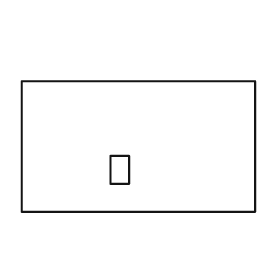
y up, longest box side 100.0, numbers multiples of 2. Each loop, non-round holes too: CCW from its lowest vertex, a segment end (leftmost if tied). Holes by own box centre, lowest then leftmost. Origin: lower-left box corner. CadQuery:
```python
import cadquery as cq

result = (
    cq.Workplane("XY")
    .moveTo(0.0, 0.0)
    .lineTo(100.0, 0.0)
    .lineTo(100.0, 56.0)
    .lineTo(0.0, 56.0)
    .close()
    .moveTo(38.0, 12.0)
    .lineTo(46.0, 12.0)
    .lineTo(46.0, 24.0)
    .lineTo(38.0, 24.0)
    .close()
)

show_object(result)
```